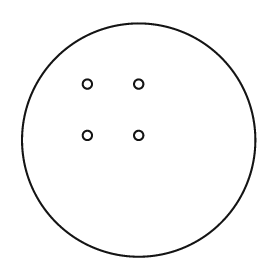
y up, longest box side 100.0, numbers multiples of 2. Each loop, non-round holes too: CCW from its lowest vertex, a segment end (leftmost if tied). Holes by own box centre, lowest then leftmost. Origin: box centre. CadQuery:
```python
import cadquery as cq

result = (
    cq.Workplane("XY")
    .moveTo(0.0, 0.0)
    .circle(50.0)
    .moveTo(-22.0, 2.0)
    .circle(2.0)
    .moveTo(0.0, 2.0)
    .circle(2.0)
    .moveTo(-22.0, 24.0)
    .circle(2.0)
    .moveTo(0.0, 24.0)
    .circle(2.0)
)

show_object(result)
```